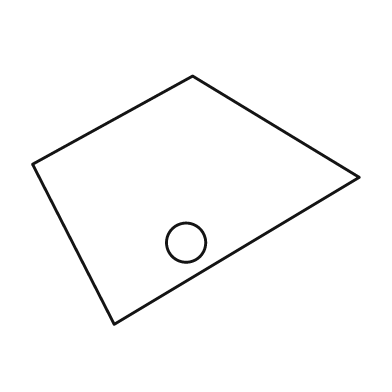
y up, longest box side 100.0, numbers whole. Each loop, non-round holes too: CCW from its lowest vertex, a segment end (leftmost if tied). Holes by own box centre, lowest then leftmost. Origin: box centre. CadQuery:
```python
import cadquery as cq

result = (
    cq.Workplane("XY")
    .moveTo(-25.0, -38.0)
    .lineTo(50.0, 7.0)
    .lineTo(-1.0, 38.0)
    .lineTo(-50.0, 11.0)
    .close()
    .moveTo(-3.0, -13.0)
    .circle(6.0)
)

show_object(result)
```